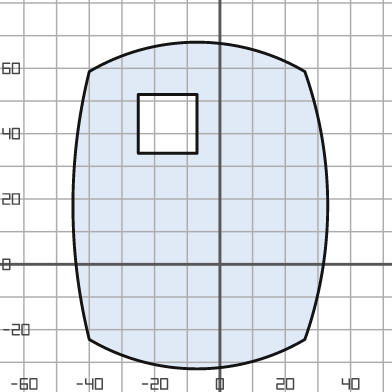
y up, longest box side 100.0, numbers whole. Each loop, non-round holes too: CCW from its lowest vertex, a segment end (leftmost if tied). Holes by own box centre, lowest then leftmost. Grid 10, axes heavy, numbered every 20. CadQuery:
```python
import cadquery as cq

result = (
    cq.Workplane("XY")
    .moveTo(-40.0, -23.0)
    .threePointArc((-7.0, -32.0), (26.0, -23.0))
    .threePointArc((33.0, 18.0), (26.0, 59.0))
    .threePointArc((-7.0, 68.0), (-40.0, 59.0))
    .threePointArc((-45.0, 18.0), (-40.0, -23.0))
    .close()
    .moveTo(-25.0, 34.0)
    .lineTo(-7.0, 34.0)
    .lineTo(-7.0, 52.0)
    .lineTo(-25.0, 52.0)
    .close()
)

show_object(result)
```